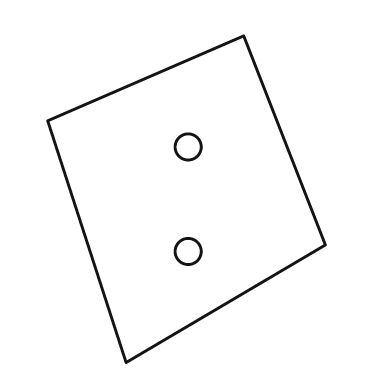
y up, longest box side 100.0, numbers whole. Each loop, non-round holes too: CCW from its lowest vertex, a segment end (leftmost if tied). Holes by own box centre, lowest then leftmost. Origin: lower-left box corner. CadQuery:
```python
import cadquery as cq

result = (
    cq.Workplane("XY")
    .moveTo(24.0, 0.0)
    .lineTo(85.0, 36.0)
    .lineTo(60.0, 100.0)
    .lineTo(0.0, 74.0)
    .close()
    .moveTo(43.0, 34.0)
    .circle(4.0)
    .moveTo(43.0, 66.0)
    .circle(4.0)
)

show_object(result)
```